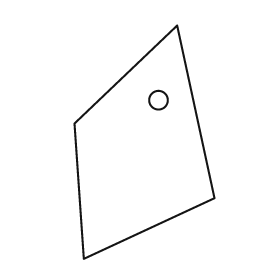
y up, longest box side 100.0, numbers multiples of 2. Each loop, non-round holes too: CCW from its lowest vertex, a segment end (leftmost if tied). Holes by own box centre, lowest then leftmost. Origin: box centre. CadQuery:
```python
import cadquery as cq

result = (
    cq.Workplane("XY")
    .moveTo(-26.0, -50.0)
    .lineTo(30.0, -24.0)
    .lineTo(14.0, 50.0)
    .lineTo(-30.0, 8.0)
    .close()
    .moveTo(6.0, 18.0)
    .circle(4.0)
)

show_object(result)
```